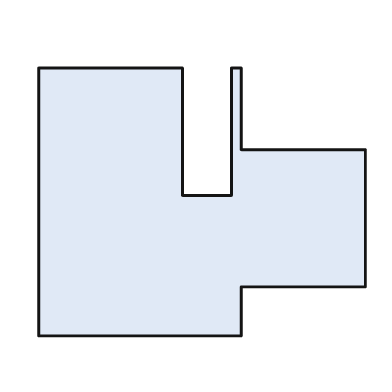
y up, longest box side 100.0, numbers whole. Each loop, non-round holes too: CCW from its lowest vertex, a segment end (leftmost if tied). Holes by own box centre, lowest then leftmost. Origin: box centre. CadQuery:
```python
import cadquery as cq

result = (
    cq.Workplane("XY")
    .moveTo(-50.0, -41.0)
    .lineTo(12.0, -41.0)
    .lineTo(12.0, -26.0)
    .lineTo(50.0, -26.0)
    .lineTo(50.0, 16.0)
    .lineTo(12.0, 16.0)
    .lineTo(12.0, 41.0)
    .lineTo(9.0, 41.0)
    .lineTo(9.0, 2.0)
    .lineTo(-6.0, 2.0)
    .lineTo(-6.0, 41.0)
    .lineTo(-50.0, 41.0)
    .close()
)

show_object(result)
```